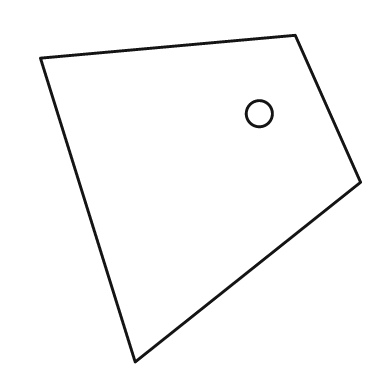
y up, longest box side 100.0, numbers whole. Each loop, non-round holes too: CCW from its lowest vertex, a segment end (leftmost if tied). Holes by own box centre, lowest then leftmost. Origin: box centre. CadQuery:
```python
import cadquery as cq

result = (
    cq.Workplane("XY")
    .moveTo(-20.0, -50.0)
    .lineTo(49.0, 5.0)
    .lineTo(29.0, 50.0)
    .lineTo(-49.0, 43.0)
    .close()
    .moveTo(18.0, 26.0)
    .circle(4.0)
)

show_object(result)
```